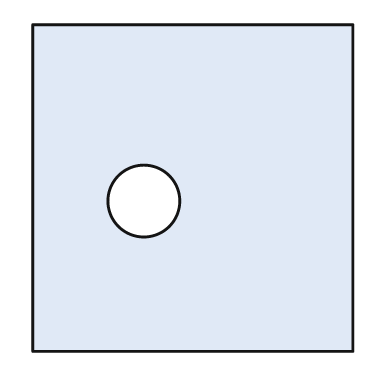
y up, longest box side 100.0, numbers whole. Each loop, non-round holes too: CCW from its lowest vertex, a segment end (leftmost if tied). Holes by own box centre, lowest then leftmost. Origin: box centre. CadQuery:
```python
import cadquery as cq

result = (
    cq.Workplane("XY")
    .moveTo(-49.0, -50.0)
    .lineTo(49.0, -50.0)
    .lineTo(49.0, 50.0)
    .lineTo(-49.0, 50.0)
    .close()
    .moveTo(-15.0, -4.0)
    .circle(11.0)
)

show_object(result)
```